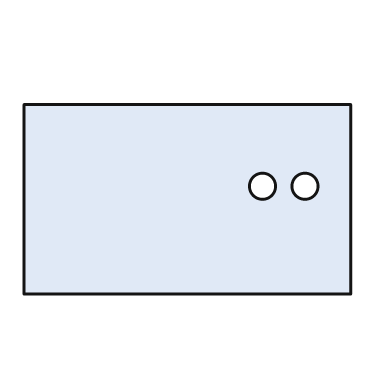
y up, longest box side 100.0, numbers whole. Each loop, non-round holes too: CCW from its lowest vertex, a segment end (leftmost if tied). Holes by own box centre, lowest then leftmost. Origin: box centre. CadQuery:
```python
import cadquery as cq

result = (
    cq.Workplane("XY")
    .moveTo(-50.0, -29.0)
    .lineTo(50.0, -29.0)
    .lineTo(50.0, 29.0)
    .lineTo(-50.0, 29.0)
    .close()
    .moveTo(23.0, 4.0)
    .circle(4.0)
    .moveTo(36.0, 4.0)
    .circle(4.0)
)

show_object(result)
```